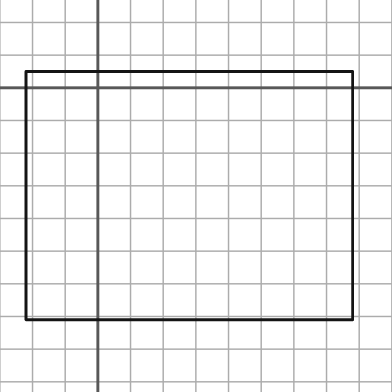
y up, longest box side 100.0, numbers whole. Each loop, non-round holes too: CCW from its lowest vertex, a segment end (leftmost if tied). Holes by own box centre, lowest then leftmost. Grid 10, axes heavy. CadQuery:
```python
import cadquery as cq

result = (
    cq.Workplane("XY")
    .moveTo(-22.0, -71.0)
    .lineTo(78.0, -71.0)
    .lineTo(78.0, 5.0)
    .lineTo(-22.0, 5.0)
    .close()
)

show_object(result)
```